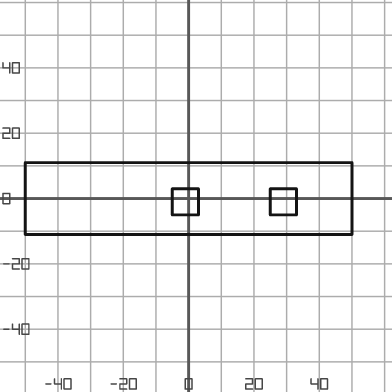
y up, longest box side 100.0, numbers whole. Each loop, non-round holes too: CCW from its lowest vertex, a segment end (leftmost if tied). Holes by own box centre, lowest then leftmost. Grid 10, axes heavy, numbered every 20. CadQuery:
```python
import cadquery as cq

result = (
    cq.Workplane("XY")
    .moveTo(-50.0, -11.0)
    .lineTo(50.0, -11.0)
    .lineTo(50.0, 11.0)
    .lineTo(-50.0, 11.0)
    .close()
    .moveTo(-5.0, -5.0)
    .lineTo(3.0, -5.0)
    .lineTo(3.0, 3.0)
    .lineTo(-5.0, 3.0)
    .close()
    .moveTo(25.0, -5.0)
    .lineTo(33.0, -5.0)
    .lineTo(33.0, 3.0)
    .lineTo(25.0, 3.0)
    .close()
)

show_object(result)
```